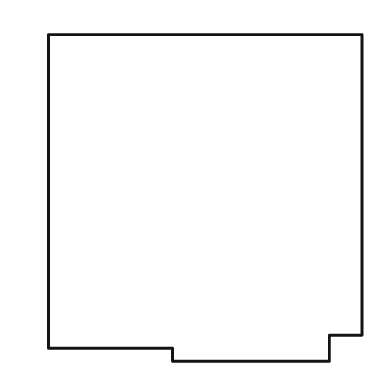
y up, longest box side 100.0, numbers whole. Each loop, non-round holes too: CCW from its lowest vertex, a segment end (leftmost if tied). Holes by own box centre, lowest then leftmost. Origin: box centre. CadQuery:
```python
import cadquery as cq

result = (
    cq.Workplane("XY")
    .moveTo(-10.0, -50.0)
    .lineTo(38.0, -50.0)
    .lineTo(38.0, -42.0)
    .lineTo(48.0, -42.0)
    .lineTo(48.0, 50.0)
    .lineTo(-48.0, 50.0)
    .lineTo(-48.0, -46.0)
    .lineTo(-10.0, -46.0)
    .close()
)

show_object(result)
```